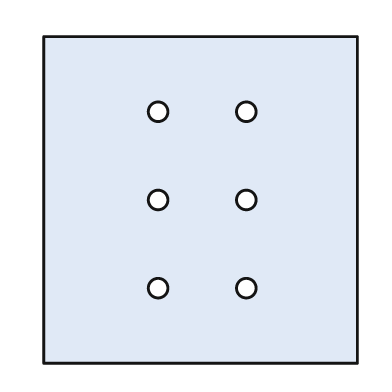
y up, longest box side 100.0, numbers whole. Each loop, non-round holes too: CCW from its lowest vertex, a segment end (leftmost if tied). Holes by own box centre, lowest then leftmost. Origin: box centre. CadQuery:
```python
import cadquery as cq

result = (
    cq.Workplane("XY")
    .moveTo(-48.0, -50.0)
    .lineTo(48.0, -50.0)
    .lineTo(48.0, 50.0)
    .lineTo(-48.0, 50.0)
    .close()
    .moveTo(-13.0, -27.0)
    .circle(3.0)
    .moveTo(14.0, -27.0)
    .circle(3.0)
    .moveTo(-13.0, 0.0)
    .circle(3.0)
    .moveTo(14.0, 0.0)
    .circle(3.0)
    .moveTo(-13.0, 27.0)
    .circle(3.0)
    .moveTo(14.0, 27.0)
    .circle(3.0)
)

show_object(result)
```